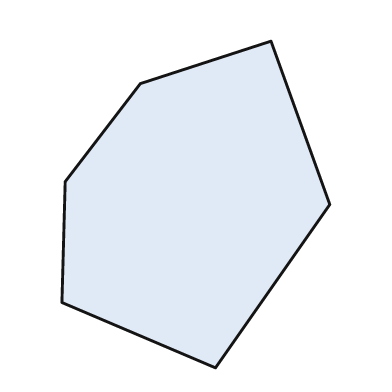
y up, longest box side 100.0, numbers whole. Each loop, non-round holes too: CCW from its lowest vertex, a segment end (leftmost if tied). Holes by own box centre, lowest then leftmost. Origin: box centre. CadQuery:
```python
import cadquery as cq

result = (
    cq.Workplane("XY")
    .moveTo(6.0, -50.0)
    .lineTo(41.0, 0.0)
    .lineTo(23.0, 50.0)
    .lineTo(-17.0, 37.0)
    .lineTo(-40.0, 7.0)
    .lineTo(-41.0, -30.0)
    .close()
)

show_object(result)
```